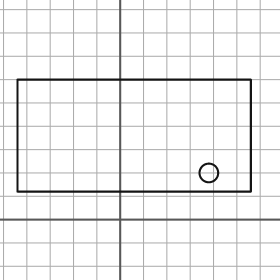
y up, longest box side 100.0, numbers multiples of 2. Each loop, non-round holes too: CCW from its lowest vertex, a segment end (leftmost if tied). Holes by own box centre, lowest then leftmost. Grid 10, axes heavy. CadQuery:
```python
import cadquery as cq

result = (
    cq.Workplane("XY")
    .moveTo(-44.0, 12.0)
    .lineTo(56.0, 12.0)
    .lineTo(56.0, 60.0)
    .lineTo(-44.0, 60.0)
    .close()
    .moveTo(38.0, 20.0)
    .circle(4.0)
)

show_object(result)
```